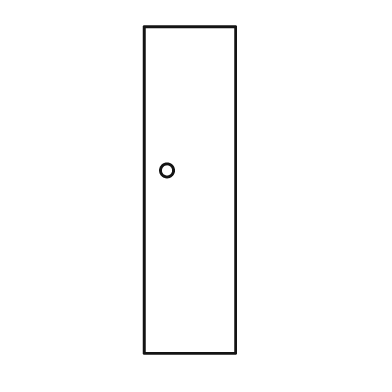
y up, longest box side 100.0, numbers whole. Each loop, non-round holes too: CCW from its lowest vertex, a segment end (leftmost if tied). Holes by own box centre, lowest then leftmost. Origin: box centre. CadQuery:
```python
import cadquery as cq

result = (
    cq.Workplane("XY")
    .moveTo(-14.0, -50.0)
    .lineTo(14.0, -50.0)
    .lineTo(14.0, 50.0)
    .lineTo(-14.0, 50.0)
    .close()
    .moveTo(-7.0, 6.0)
    .circle(2.0)
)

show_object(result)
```